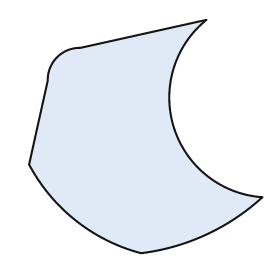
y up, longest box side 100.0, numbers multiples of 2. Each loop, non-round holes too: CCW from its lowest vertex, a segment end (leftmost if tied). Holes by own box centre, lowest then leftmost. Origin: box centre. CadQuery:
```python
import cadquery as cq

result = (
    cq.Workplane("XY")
    .moveTo(-2.0, -50.0)
    .threePointArc((26.0, -42.0), (50.0, -26.0))
    .threePointArc((12.0, 4.0), (26.0, 50.0))
    .lineTo(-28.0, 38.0)
    .threePointArc((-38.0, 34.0), (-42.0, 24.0))
    .lineTo(-50.0, -12.0)
    .threePointArc((-30.0, -36.0), (-2.0, -50.0))
    .close()
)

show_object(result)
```